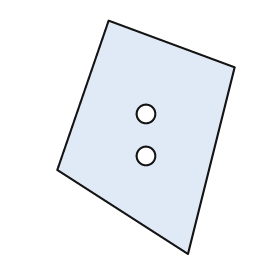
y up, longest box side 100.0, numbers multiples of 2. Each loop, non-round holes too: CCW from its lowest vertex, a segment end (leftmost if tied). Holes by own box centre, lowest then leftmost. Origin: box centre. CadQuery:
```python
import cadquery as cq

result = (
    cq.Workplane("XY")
    .moveTo(18.0, -50.0)
    .lineTo(38.0, 30.0)
    .lineTo(-16.0, 50.0)
    .lineTo(-38.0, -14.0)
    .close()
    .moveTo(0.0, -8.0)
    .circle(4.0)
    .moveTo(0.0, 10.0)
    .circle(4.0)
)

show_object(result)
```